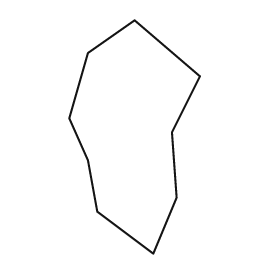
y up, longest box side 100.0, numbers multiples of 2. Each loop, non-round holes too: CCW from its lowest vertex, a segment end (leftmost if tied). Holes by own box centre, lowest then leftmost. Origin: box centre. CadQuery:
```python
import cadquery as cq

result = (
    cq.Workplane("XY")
    .moveTo(8.0, -50.0)
    .lineTo(18.0, -26.0)
    .lineTo(16.0, 2.0)
    .lineTo(28.0, 26.0)
    .lineTo(0.0, 50.0)
    .lineTo(-20.0, 36.0)
    .lineTo(-28.0, 8.0)
    .lineTo(-20.0, -10.0)
    .lineTo(-16.0, -32.0)
    .close()
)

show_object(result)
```